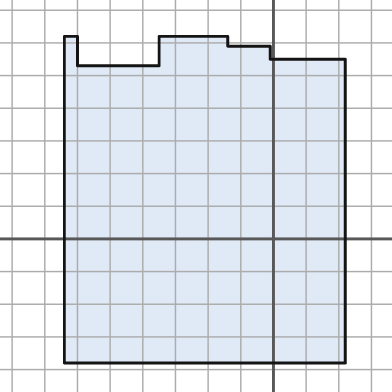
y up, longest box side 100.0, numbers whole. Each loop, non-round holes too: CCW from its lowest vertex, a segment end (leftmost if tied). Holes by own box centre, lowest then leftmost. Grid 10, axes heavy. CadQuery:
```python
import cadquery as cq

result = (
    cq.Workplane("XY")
    .moveTo(-64.0, -38.0)
    .lineTo(22.0, -38.0)
    .lineTo(22.0, 55.0)
    .lineTo(-1.0, 55.0)
    .lineTo(-1.0, 59.0)
    .lineTo(-14.0, 59.0)
    .lineTo(-14.0, 62.0)
    .lineTo(-35.0, 62.0)
    .lineTo(-35.0, 53.0)
    .lineTo(-60.0, 53.0)
    .lineTo(-60.0, 62.0)
    .lineTo(-64.0, 62.0)
    .close()
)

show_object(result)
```